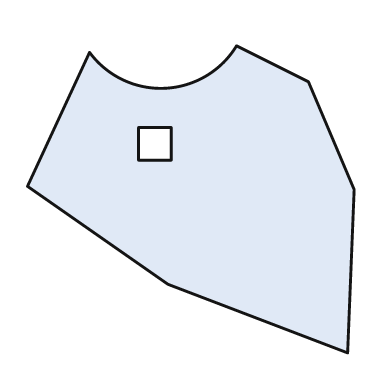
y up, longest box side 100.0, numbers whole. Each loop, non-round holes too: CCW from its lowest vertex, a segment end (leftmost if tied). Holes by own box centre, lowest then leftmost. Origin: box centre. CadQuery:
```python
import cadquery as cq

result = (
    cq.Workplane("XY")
    .moveTo(48.0, -47.0)
    .lineTo(50.0, 3.0)
    .lineTo(36.0, 36.0)
    .lineTo(14.0, 47.0)
    .threePointArc((-8.0, 34.0), (-31.0, 45.0))
    .lineTo(-50.0, 4.0)
    .lineTo(-7.0, -26.0)
    .close()
    .moveTo(-16.0, 12.0)
    .lineTo(-6.0, 12.0)
    .lineTo(-6.0, 22.0)
    .lineTo(-16.0, 22.0)
    .close()
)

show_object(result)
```